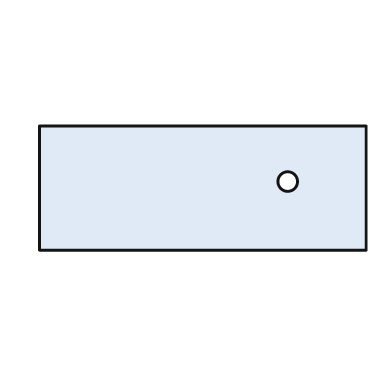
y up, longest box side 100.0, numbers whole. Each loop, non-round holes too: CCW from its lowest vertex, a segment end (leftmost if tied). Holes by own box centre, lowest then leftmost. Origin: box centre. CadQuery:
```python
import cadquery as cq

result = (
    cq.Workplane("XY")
    .moveTo(-50.0, -19.0)
    .lineTo(50.0, -19.0)
    .lineTo(50.0, 19.0)
    .lineTo(-50.0, 19.0)
    .close()
    .moveTo(26.0, 2.0)
    .circle(3.0)
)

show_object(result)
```